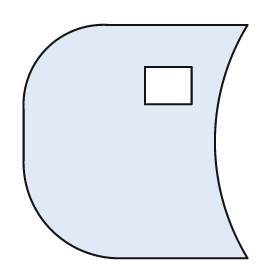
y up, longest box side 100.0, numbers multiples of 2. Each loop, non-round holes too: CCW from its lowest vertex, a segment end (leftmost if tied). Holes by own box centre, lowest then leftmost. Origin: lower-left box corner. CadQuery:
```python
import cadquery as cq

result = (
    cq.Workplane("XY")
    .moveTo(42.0, 0.0)
    .lineTo(96.0, 0.0)
    .threePointArc((82.0, 50.0), (96.0, 100.0))
    .lineTo(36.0, 100.0)
    .threePointArc((10.0, 90.0), (0.0, 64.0))
    .lineTo(0.0, 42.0)
    .threePointArc((12.0, 12.0), (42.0, 0.0))
    .close()
    .moveTo(52.0, 66.0)
    .lineTo(72.0, 66.0)
    .lineTo(72.0, 82.0)
    .lineTo(52.0, 82.0)
    .close()
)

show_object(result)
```